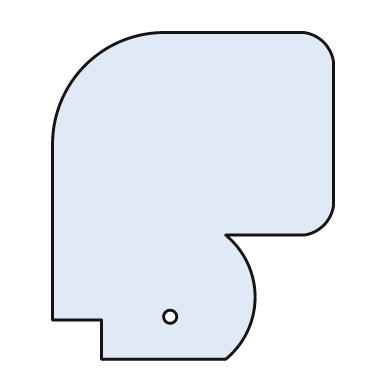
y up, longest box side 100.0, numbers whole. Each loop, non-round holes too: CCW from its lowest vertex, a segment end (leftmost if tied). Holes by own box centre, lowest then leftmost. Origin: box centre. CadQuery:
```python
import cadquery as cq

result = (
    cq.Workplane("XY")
    .moveTo(-28.0, -50.0)
    .lineTo(10.0, -50.0)
    .threePointArc((19.0, -31.0), (10.0, -12.0))
    .lineTo(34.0, -12.0)
    .threePointArc((40.0, -9.0), (43.0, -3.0))
    .lineTo(43.0, 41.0)
    .threePointArc((40.0, 47.0), (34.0, 50.0))
    .lineTo(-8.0, 50.0)
    .threePointArc((-33.0, 40.0), (-43.0, 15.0))
    .lineTo(-43.0, -38.0)
    .lineTo(-28.0, -38.0)
    .close()
    .moveTo(-7.0, -37.0)
    .circle(2.0)
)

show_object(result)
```